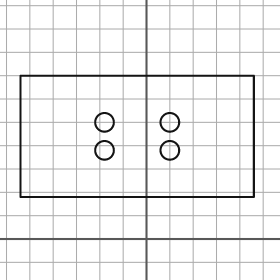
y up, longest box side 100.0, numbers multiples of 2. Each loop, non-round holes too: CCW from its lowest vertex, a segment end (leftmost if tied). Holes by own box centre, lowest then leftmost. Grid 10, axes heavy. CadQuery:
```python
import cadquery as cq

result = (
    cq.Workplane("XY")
    .moveTo(-54.0, 18.0)
    .lineTo(46.0, 18.0)
    .lineTo(46.0, 70.0)
    .lineTo(-54.0, 70.0)
    .close()
    .moveTo(-18.0, 38.0)
    .circle(4.0)
    .moveTo(10.0, 38.0)
    .circle(4.0)
    .moveTo(-18.0, 50.0)
    .circle(4.0)
    .moveTo(10.0, 50.0)
    .circle(4.0)
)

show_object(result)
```